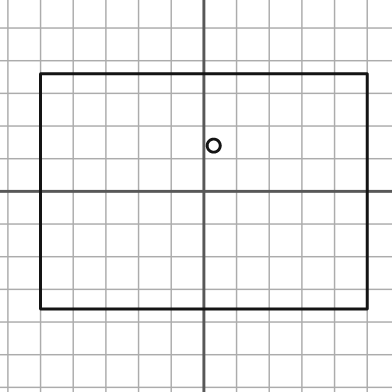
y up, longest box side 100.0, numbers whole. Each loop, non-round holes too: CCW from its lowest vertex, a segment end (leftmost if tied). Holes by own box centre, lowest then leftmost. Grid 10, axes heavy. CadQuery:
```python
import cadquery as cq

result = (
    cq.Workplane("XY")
    .moveTo(-50.0, -36.0)
    .lineTo(50.0, -36.0)
    .lineTo(50.0, 36.0)
    .lineTo(-50.0, 36.0)
    .close()
    .moveTo(3.0, 14.0)
    .circle(2.0)
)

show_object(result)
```